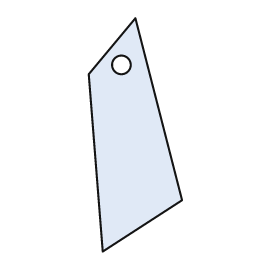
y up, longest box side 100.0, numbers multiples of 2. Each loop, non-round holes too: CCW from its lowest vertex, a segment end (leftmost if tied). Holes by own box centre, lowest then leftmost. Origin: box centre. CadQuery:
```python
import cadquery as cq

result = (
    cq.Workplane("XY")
    .moveTo(-14.0, -50.0)
    .lineTo(20.0, -28.0)
    .lineTo(0.0, 50.0)
    .lineTo(-20.0, 26.0)
    .close()
    .moveTo(-6.0, 30.0)
    .circle(4.0)
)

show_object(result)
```